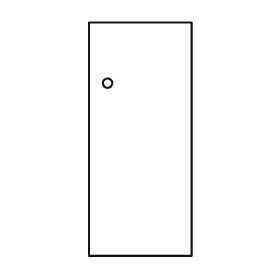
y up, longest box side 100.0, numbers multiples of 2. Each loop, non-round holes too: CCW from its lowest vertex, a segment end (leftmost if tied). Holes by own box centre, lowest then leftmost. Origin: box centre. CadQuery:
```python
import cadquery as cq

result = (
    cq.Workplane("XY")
    .moveTo(-22.0, -50.0)
    .lineTo(22.0, -50.0)
    .lineTo(22.0, 50.0)
    .lineTo(-22.0, 50.0)
    .close()
    .moveTo(-14.0, 24.0)
    .circle(2.0)
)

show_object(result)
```